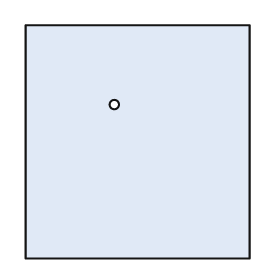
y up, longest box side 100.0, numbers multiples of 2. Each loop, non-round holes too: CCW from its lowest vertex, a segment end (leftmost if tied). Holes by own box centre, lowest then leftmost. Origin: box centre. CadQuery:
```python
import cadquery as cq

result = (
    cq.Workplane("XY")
    .moveTo(-48.0, -50.0)
    .lineTo(48.0, -50.0)
    .lineTo(48.0, 50.0)
    .lineTo(-48.0, 50.0)
    .close()
    .moveTo(-10.0, 16.0)
    .circle(2.0)
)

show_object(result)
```